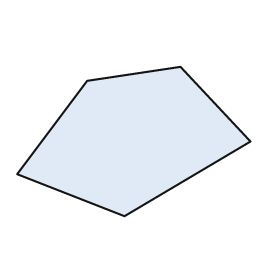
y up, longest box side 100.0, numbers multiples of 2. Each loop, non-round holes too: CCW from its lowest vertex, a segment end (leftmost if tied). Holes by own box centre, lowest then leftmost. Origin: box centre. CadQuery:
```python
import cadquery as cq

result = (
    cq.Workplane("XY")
    .moveTo(-4.0, -32.0)
    .lineTo(50.0, 0.0)
    .lineTo(20.0, 32.0)
    .lineTo(-20.0, 26.0)
    .lineTo(-50.0, -14.0)
    .close()
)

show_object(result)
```